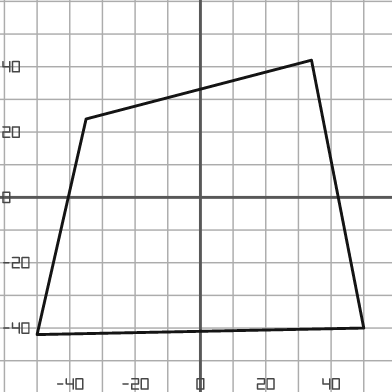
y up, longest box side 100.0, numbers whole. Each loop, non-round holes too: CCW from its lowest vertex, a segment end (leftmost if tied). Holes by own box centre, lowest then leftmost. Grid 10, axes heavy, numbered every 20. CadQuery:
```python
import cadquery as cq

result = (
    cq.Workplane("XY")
    .moveTo(-50.0, -42.0)
    .lineTo(50.0, -40.0)
    .lineTo(34.0, 42.0)
    .lineTo(-35.0, 24.0)
    .close()
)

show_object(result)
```